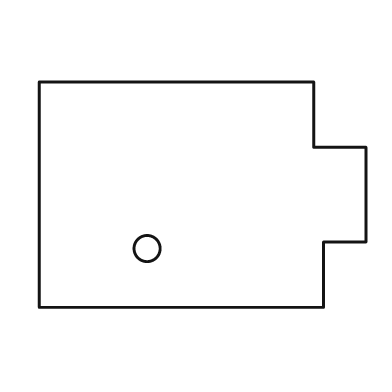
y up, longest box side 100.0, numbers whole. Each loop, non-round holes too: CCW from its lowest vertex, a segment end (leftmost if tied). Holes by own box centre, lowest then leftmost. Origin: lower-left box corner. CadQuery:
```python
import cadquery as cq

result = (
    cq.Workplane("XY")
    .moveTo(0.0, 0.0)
    .lineTo(87.0, 0.0)
    .lineTo(87.0, 20.0)
    .lineTo(100.0, 20.0)
    .lineTo(100.0, 49.0)
    .lineTo(84.0, 49.0)
    .lineTo(84.0, 69.0)
    .lineTo(0.0, 69.0)
    .close()
    .moveTo(33.0, 18.0)
    .circle(4.0)
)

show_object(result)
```